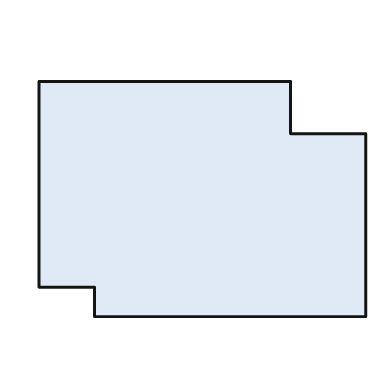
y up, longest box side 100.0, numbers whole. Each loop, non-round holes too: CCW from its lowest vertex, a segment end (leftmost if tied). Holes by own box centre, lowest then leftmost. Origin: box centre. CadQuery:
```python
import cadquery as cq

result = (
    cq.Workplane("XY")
    .moveTo(-33.0, -36.0)
    .lineTo(50.0, -36.0)
    .lineTo(50.0, 20.0)
    .lineTo(27.0, 20.0)
    .lineTo(27.0, 36.0)
    .lineTo(-50.0, 36.0)
    .lineTo(-50.0, -27.0)
    .lineTo(-33.0, -27.0)
    .close()
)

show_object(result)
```